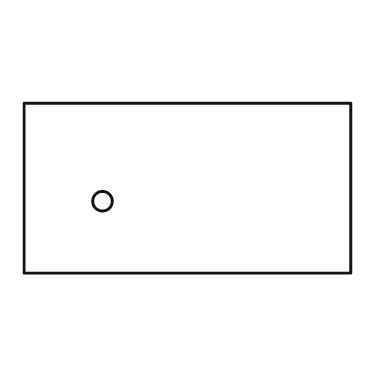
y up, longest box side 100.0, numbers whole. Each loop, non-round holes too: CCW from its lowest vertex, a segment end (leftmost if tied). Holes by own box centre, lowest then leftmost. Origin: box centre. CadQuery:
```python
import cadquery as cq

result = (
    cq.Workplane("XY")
    .moveTo(-50.0, -26.0)
    .lineTo(50.0, -26.0)
    .lineTo(50.0, 26.0)
    .lineTo(-50.0, 26.0)
    .close()
    .moveTo(-26.0, -4.0)
    .circle(3.0)
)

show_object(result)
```